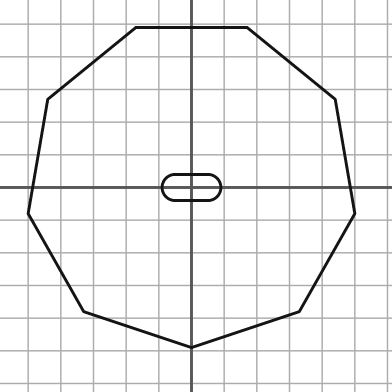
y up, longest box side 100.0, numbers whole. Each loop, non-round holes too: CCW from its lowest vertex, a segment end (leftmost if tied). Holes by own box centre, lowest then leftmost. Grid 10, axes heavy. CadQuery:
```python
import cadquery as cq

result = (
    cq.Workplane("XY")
    .moveTo(0.0, -49.0)
    .lineTo(33.0, -38.0)
    .lineTo(50.0, -8.0)
    .lineTo(44.0, 27.0)
    .lineTo(17.0, 49.0)
    .lineTo(-17.0, 49.0)
    .lineTo(-44.0, 27.0)
    .lineTo(-50.0, -8.0)
    .lineTo(-33.0, -38.0)
    .close()
    .moveTo(-5.0, -4.0)
    .lineTo(5.0, -4.0)
    .threePointArc((9.0, 0.0), (5.0, 4.0))
    .lineTo(-5.0, 4.0)
    .threePointArc((-9.0, 0.0), (-5.0, -4.0))
    .close()
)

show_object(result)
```